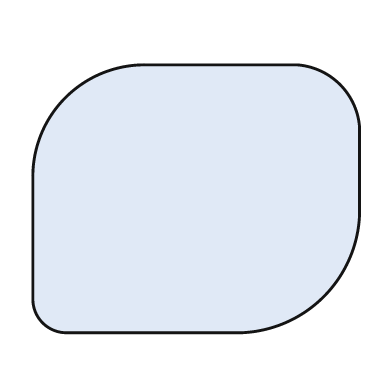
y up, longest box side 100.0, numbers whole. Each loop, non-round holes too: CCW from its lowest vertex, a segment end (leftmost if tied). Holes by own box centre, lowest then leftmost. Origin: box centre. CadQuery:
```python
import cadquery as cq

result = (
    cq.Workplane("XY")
    .moveTo(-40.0, -41.0)
    .lineTo(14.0, -41.0)
    .threePointArc((39.0, -30.0), (50.0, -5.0))
    .lineTo(50.0, 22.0)
    .threePointArc((44.0, 35.0), (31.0, 41.0))
    .lineTo(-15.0, 41.0)
    .threePointArc((-40.0, 31.0), (-50.0, 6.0))
    .lineTo(-50.0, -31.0)
    .threePointArc((-47.0, -38.0), (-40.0, -41.0))
    .close()
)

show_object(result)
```